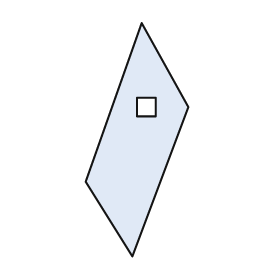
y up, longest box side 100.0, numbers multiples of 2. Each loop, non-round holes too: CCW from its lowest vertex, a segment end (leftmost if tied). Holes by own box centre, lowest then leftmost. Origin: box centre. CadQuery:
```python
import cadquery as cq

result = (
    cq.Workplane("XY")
    .moveTo(-2.0, -50.0)
    .lineTo(22.0, 14.0)
    .lineTo(2.0, 50.0)
    .lineTo(-22.0, -18.0)
    .close()
    .moveTo(0.0, 10.0)
    .lineTo(8.0, 10.0)
    .lineTo(8.0, 18.0)
    .lineTo(0.0, 18.0)
    .close()
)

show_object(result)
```